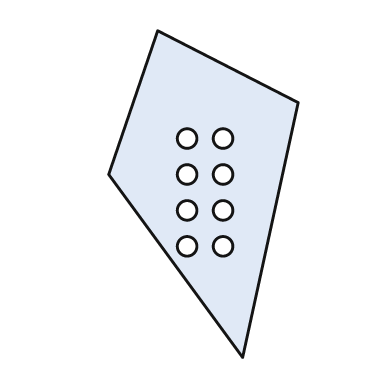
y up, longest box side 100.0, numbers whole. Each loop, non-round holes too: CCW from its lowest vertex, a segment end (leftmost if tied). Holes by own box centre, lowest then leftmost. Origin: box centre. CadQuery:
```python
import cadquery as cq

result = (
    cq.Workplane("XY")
    .moveTo(12.0, -50.0)
    .lineTo(29.0, 28.0)
    .lineTo(-14.0, 50.0)
    .lineTo(-29.0, 6.0)
    .close()
    .moveTo(-5.0, -16.0)
    .circle(3.0)
    .moveTo(6.0, -16.0)
    .circle(3.0)
    .moveTo(-5.0, -5.0)
    .circle(3.0)
    .moveTo(6.0, -5.0)
    .circle(3.0)
    .moveTo(-5.0, 6.0)
    .circle(3.0)
    .moveTo(6.0, 6.0)
    .circle(3.0)
    .moveTo(-5.0, 17.0)
    .circle(3.0)
    .moveTo(6.0, 17.0)
    .circle(3.0)
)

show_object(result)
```